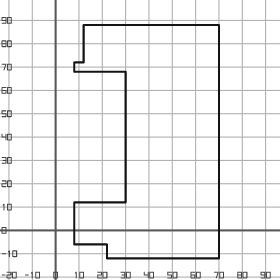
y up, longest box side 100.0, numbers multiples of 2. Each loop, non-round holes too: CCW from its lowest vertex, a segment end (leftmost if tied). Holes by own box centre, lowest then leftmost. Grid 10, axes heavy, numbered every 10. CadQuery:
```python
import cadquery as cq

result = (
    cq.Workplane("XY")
    .moveTo(22.0, -12.0)
    .lineTo(70.0, -12.0)
    .lineTo(70.0, 88.0)
    .lineTo(12.0, 88.0)
    .lineTo(12.0, 72.0)
    .lineTo(8.0, 72.0)
    .lineTo(8.0, 68.0)
    .lineTo(30.0, 68.0)
    .lineTo(30.0, 12.0)
    .lineTo(8.0, 12.0)
    .lineTo(8.0, -6.0)
    .lineTo(22.0, -6.0)
    .close()
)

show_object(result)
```